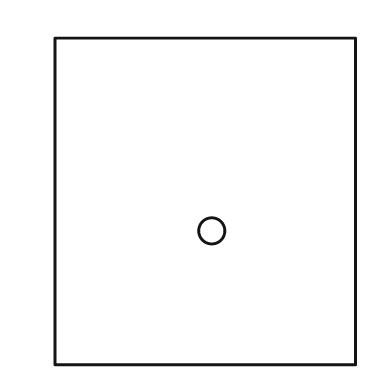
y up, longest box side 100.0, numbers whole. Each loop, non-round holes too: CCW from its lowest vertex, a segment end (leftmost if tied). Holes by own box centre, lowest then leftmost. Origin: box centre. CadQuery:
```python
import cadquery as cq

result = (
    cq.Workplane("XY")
    .moveTo(-46.0, -50.0)
    .lineTo(46.0, -50.0)
    .lineTo(46.0, 50.0)
    .lineTo(-46.0, 50.0)
    .close()
    .moveTo(2.0, -9.0)
    .circle(4.0)
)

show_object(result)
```